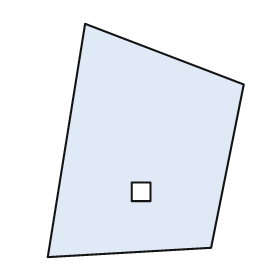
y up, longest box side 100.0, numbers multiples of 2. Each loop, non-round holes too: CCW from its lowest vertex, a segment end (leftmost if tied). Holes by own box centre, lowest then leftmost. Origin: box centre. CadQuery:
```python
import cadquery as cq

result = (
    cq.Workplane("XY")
    .moveTo(-42.0, -50.0)
    .lineTo(28.0, -46.0)
    .lineTo(42.0, 24.0)
    .lineTo(-26.0, 50.0)
    .close()
    .moveTo(-6.0, -26.0)
    .lineTo(2.0, -26.0)
    .lineTo(2.0, -18.0)
    .lineTo(-6.0, -18.0)
    .close()
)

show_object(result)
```